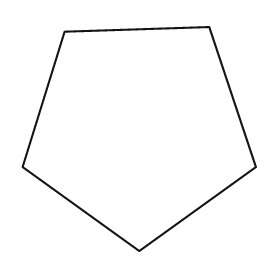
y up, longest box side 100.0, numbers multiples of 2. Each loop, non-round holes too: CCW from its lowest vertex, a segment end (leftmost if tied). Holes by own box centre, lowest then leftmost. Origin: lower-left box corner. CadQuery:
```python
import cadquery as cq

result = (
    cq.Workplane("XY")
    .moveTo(50.0, 0.0)
    .lineTo(100.0, 36.0)
    .lineTo(80.0, 96.0)
    .lineTo(18.0, 94.0)
    .lineTo(0.0, 36.0)
    .close()
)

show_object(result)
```